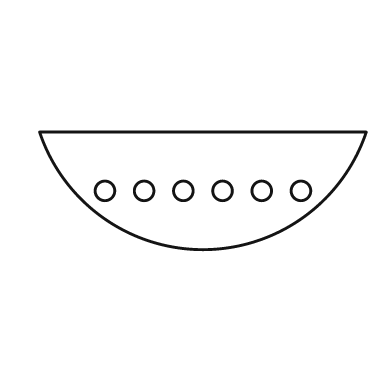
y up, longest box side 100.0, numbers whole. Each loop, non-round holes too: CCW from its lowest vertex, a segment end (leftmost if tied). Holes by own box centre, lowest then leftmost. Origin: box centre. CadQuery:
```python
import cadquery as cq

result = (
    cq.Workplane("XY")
    .moveTo(-50.0, 18.0)
    .threePointArc((0.0, -18.0), (50.0, 18.0))
    .close()
    .moveTo(-30.0, 0.0)
    .circle(3.0)
    .moveTo(-18.0, 0.0)
    .circle(3.0)
    .moveTo(-6.0, 0.0)
    .circle(3.0)
    .moveTo(6.0, 0.0)
    .circle(3.0)
    .moveTo(18.0, 0.0)
    .circle(3.0)
    .moveTo(30.0, 0.0)
    .circle(3.0)
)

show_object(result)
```